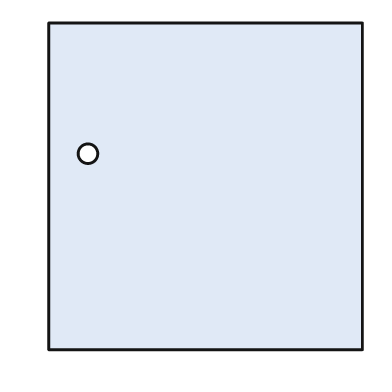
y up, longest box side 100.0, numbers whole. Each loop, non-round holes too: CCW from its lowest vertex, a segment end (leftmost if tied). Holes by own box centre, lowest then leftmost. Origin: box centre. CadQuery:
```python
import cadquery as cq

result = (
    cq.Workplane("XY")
    .moveTo(-48.0, -50.0)
    .lineTo(48.0, -50.0)
    .lineTo(48.0, 50.0)
    .lineTo(-48.0, 50.0)
    .close()
    .moveTo(-36.0, 10.0)
    .circle(3.0)
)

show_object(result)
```